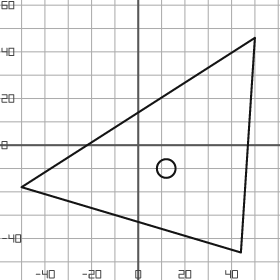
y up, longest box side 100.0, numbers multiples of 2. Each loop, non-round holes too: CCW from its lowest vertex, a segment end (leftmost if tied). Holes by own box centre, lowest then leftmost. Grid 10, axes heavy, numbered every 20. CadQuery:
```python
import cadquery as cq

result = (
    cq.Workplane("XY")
    .moveTo(44.0, -46.0)
    .lineTo(50.0, 46.0)
    .lineTo(-50.0, -18.0)
    .close()
    .moveTo(12.0, -10.0)
    .circle(4.0)
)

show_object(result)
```